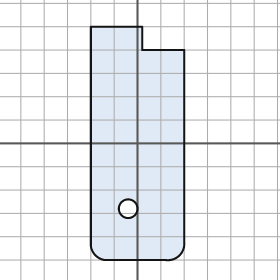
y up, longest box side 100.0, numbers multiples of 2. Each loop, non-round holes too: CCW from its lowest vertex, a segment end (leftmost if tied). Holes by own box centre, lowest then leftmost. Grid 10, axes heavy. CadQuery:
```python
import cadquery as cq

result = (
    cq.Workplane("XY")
    .moveTo(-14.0, -50.0)
    .lineTo(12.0, -50.0)
    .threePointArc((18.0, -48.0), (20.0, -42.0))
    .lineTo(20.0, 40.0)
    .lineTo(2.0, 40.0)
    .lineTo(2.0, 50.0)
    .lineTo(-20.0, 50.0)
    .lineTo(-20.0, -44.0)
    .threePointArc((-18.0, -48.0), (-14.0, -50.0))
    .close()
    .moveTo(-4.0, -28.0)
    .circle(4.0)
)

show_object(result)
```